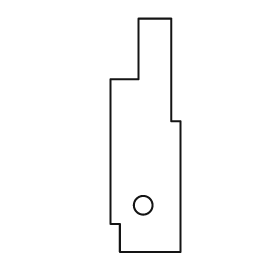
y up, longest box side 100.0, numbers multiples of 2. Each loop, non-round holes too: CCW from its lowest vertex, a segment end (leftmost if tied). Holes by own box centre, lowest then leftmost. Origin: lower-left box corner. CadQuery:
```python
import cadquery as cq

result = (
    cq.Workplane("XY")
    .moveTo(4.0, 0.0)
    .lineTo(30.0, 0.0)
    .lineTo(30.0, 56.0)
    .lineTo(26.0, 56.0)
    .lineTo(26.0, 100.0)
    .lineTo(12.0, 100.0)
    .lineTo(12.0, 74.0)
    .lineTo(0.0, 74.0)
    .lineTo(0.0, 12.0)
    .lineTo(4.0, 12.0)
    .close()
    .moveTo(14.0, 20.0)
    .circle(4.0)
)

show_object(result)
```